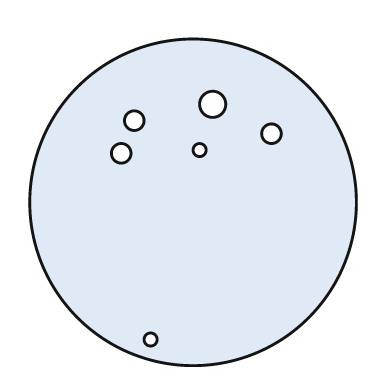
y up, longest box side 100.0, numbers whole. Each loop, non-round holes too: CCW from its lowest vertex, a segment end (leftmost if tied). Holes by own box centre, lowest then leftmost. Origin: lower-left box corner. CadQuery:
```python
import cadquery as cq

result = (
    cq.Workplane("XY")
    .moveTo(50.0, 50.0)
    .circle(50.0)
    .moveTo(37.0, 8.0)
    .circle(2.0)
    .moveTo(28.0, 65.0)
    .circle(3.0)
    .moveTo(52.0, 66.0)
    .circle(2.0)
    .moveTo(74.0, 71.0)
    .circle(3.0)
    .moveTo(32.0, 75.0)
    .circle(3.0)
    .moveTo(56.0, 80.0)
    .circle(4.0)
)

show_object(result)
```